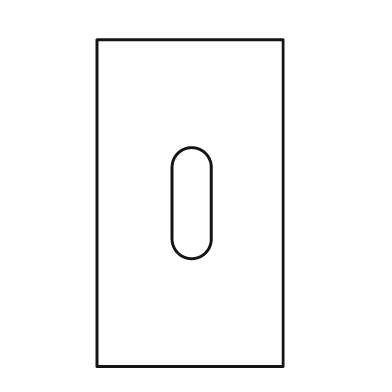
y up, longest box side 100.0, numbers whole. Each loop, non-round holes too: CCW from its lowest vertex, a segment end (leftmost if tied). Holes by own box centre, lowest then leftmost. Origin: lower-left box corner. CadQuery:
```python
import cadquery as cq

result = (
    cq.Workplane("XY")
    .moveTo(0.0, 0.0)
    .lineTo(57.0, 0.0)
    .lineTo(57.0, 100.0)
    .lineTo(0.0, 100.0)
    .close()
    .moveTo(23.0, 39.0)
    .threePointArc((29.0, 33.0), (35.0, 39.0))
    .lineTo(35.0, 61.0)
    .threePointArc((29.0, 67.0), (23.0, 61.0))
    .close()
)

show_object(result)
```